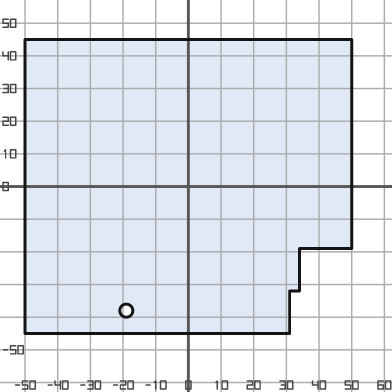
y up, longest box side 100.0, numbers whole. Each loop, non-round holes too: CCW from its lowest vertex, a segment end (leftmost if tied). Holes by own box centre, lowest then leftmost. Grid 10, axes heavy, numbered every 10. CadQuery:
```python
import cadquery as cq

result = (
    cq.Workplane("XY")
    .moveTo(-50.0, -45.0)
    .lineTo(31.0, -45.0)
    .lineTo(31.0, -32.0)
    .lineTo(34.0, -32.0)
    .lineTo(34.0, -19.0)
    .lineTo(50.0, -19.0)
    .lineTo(50.0, 45.0)
    .lineTo(-50.0, 45.0)
    .close()
    .moveTo(-19.0, -38.0)
    .circle(2.0)
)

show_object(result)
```